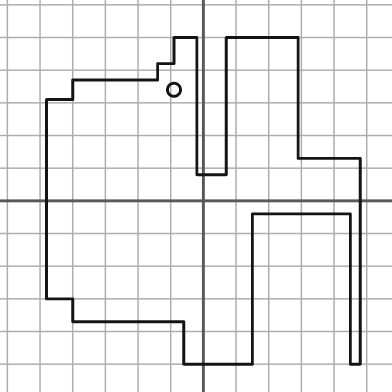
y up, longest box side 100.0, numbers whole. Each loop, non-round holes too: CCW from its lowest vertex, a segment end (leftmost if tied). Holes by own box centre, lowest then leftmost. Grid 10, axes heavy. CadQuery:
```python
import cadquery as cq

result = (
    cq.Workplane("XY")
    .moveTo(-6.0, -50.0)
    .lineTo(15.0, -50.0)
    .lineTo(15.0, -4.0)
    .lineTo(45.0, -4.0)
    .lineTo(45.0, -50.0)
    .lineTo(48.0, -50.0)
    .lineTo(48.0, 13.0)
    .lineTo(29.0, 13.0)
    .lineTo(29.0, 50.0)
    .lineTo(7.0, 50.0)
    .lineTo(7.0, 8.0)
    .lineTo(-2.0, 8.0)
    .lineTo(-2.0, 50.0)
    .lineTo(-9.0, 50.0)
    .lineTo(-9.0, 42.0)
    .lineTo(-14.0, 42.0)
    .lineTo(-14.0, 37.0)
    .lineTo(-40.0, 37.0)
    .lineTo(-40.0, 31.0)
    .lineTo(-48.0, 31.0)
    .lineTo(-48.0, -30.0)
    .lineTo(-40.0, -30.0)
    .lineTo(-40.0, -37.0)
    .lineTo(-6.0, -37.0)
    .close()
    .moveTo(-9.0, 34.0)
    .circle(2.0)
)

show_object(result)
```